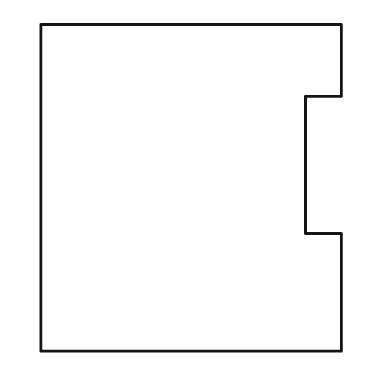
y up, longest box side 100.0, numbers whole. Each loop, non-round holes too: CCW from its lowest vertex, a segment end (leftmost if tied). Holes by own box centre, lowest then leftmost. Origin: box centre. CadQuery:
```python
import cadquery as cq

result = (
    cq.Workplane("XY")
    .moveTo(-46.0, -50.0)
    .lineTo(46.0, -50.0)
    .lineTo(46.0, -14.0)
    .lineTo(35.0, -14.0)
    .lineTo(35.0, 28.0)
    .lineTo(46.0, 28.0)
    .lineTo(46.0, 50.0)
    .lineTo(-46.0, 50.0)
    .close()
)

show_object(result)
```